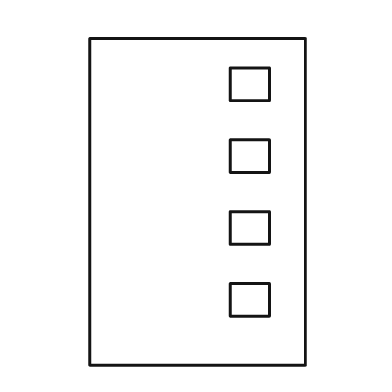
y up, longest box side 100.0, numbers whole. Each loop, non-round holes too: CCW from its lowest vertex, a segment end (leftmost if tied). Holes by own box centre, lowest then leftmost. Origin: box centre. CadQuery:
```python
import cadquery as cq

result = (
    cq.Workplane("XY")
    .moveTo(-33.0, -50.0)
    .lineTo(33.0, -50.0)
    .lineTo(33.0, 50.0)
    .lineTo(-33.0, 50.0)
    .close()
    .moveTo(10.0, -35.0)
    .lineTo(22.0, -35.0)
    .lineTo(22.0, -25.0)
    .lineTo(10.0, -25.0)
    .close()
    .moveTo(10.0, -13.0)
    .lineTo(22.0, -13.0)
    .lineTo(22.0, -3.0)
    .lineTo(10.0, -3.0)
    .close()
    .moveTo(10.0, 9.0)
    .lineTo(22.0, 9.0)
    .lineTo(22.0, 19.0)
    .lineTo(10.0, 19.0)
    .close()
    .moveTo(10.0, 31.0)
    .lineTo(22.0, 31.0)
    .lineTo(22.0, 41.0)
    .lineTo(10.0, 41.0)
    .close()
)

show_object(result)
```